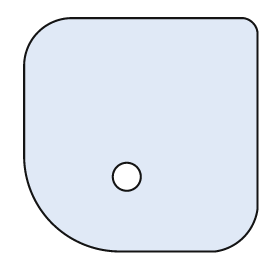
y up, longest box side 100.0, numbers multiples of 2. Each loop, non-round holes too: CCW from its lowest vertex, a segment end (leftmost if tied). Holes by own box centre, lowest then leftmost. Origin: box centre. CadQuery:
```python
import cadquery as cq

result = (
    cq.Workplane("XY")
    .moveTo(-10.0, -50.0)
    .lineTo(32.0, -50.0)
    .threePointArc((44.0, -44.0), (50.0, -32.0))
    .lineTo(50.0, 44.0)
    .threePointArc((48.0, 48.0), (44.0, 50.0))
    .lineTo(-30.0, 50.0)
    .threePointArc((-44.0, 44.0), (-50.0, 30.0))
    .lineTo(-50.0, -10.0)
    .threePointArc((-38.0, -38.0), (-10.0, -50.0))
    .close()
    .moveTo(-6.0, -18.0)
    .circle(6.0)
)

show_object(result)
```